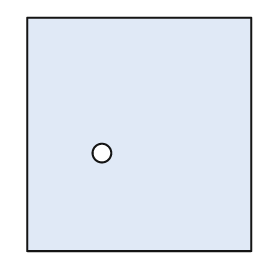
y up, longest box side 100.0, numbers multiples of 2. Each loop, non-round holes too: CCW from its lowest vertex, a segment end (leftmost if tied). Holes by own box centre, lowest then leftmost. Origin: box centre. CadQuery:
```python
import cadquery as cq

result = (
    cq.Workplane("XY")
    .moveTo(-48.0, -50.0)
    .lineTo(48.0, -50.0)
    .lineTo(48.0, 50.0)
    .lineTo(-48.0, 50.0)
    .close()
    .moveTo(-16.0, -8.0)
    .circle(4.0)
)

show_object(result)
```